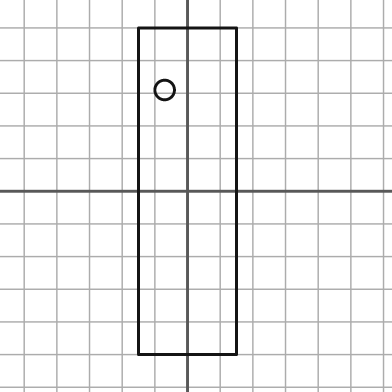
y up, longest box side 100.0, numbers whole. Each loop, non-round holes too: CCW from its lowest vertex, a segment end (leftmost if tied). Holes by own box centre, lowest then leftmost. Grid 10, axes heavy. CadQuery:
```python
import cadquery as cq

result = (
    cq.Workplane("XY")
    .moveTo(-15.0, -50.0)
    .lineTo(15.0, -50.0)
    .lineTo(15.0, 50.0)
    .lineTo(-15.0, 50.0)
    .close()
    .moveTo(-7.0, 31.0)
    .circle(3.0)
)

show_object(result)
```